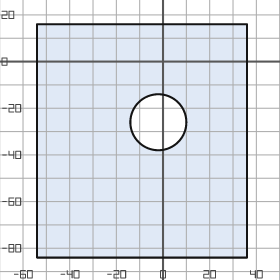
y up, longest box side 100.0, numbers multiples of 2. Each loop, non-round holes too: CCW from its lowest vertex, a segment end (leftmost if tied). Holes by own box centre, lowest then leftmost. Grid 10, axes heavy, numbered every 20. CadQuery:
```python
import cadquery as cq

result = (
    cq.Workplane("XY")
    .moveTo(-54.0, -84.0)
    .lineTo(36.0, -84.0)
    .lineTo(36.0, 16.0)
    .lineTo(-54.0, 16.0)
    .close()
    .moveTo(-2.0, -26.0)
    .circle(12.0)
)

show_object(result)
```